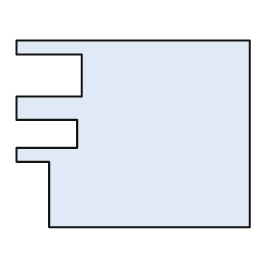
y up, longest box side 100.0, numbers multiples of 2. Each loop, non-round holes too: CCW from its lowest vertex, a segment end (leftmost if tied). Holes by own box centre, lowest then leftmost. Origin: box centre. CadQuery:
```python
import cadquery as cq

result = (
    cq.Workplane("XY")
    .moveTo(-36.0, -40.0)
    .lineTo(50.0, -40.0)
    .lineTo(50.0, 40.0)
    .lineTo(-50.0, 40.0)
    .lineTo(-50.0, 34.0)
    .lineTo(-22.0, 34.0)
    .lineTo(-22.0, 16.0)
    .lineTo(-50.0, 16.0)
    .lineTo(-50.0, 6.0)
    .lineTo(-24.0, 6.0)
    .lineTo(-24.0, -6.0)
    .lineTo(-50.0, -6.0)
    .lineTo(-50.0, -12.0)
    .lineTo(-36.0, -12.0)
    .close()
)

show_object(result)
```